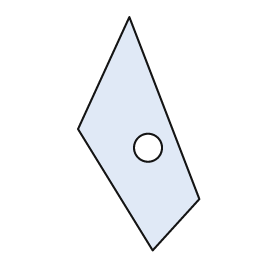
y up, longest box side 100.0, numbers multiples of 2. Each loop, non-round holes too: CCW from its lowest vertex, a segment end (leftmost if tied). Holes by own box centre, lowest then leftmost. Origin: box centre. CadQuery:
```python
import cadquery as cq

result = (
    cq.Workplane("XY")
    .moveTo(6.0, -50.0)
    .lineTo(26.0, -28.0)
    .lineTo(-4.0, 50.0)
    .lineTo(-26.0, 2.0)
    .close()
    .moveTo(4.0, -6.0)
    .circle(6.0)
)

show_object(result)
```